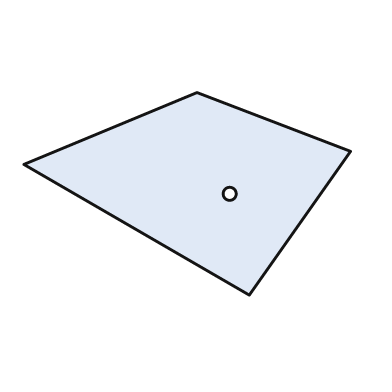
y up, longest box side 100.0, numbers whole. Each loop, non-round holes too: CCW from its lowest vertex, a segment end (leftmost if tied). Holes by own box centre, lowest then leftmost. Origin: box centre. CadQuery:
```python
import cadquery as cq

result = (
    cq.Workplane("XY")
    .moveTo(19.0, -31.0)
    .lineTo(50.0, 13.0)
    .lineTo(3.0, 31.0)
    .lineTo(-50.0, 9.0)
    .close()
    .moveTo(13.0, 0.0)
    .circle(2.0)
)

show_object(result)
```